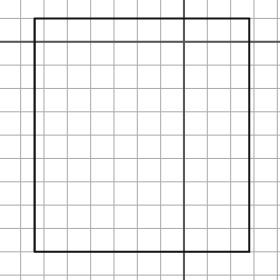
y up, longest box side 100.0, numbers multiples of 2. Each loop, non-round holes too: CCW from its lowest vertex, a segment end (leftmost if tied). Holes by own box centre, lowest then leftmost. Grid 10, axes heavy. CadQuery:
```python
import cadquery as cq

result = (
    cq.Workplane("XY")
    .moveTo(-64.0, -90.0)
    .lineTo(28.0, -90.0)
    .lineTo(28.0, 10.0)
    .lineTo(-64.0, 10.0)
    .close()
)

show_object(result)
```